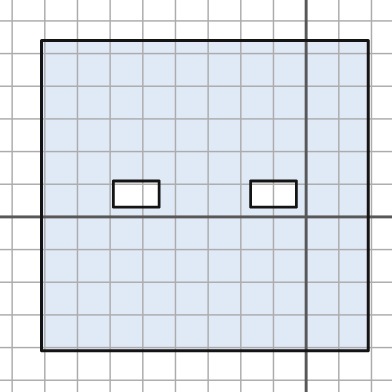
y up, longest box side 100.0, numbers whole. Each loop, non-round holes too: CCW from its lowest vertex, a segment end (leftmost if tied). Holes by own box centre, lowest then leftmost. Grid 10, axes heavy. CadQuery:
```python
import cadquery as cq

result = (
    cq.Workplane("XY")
    .moveTo(-81.0, -41.0)
    .lineTo(19.0, -41.0)
    .lineTo(19.0, 54.0)
    .lineTo(-81.0, 54.0)
    .close()
    .moveTo(-59.0, 3.0)
    .lineTo(-45.0, 3.0)
    .lineTo(-45.0, 11.0)
    .lineTo(-59.0, 11.0)
    .close()
    .moveTo(-17.0, 3.0)
    .lineTo(-3.0, 3.0)
    .lineTo(-3.0, 11.0)
    .lineTo(-17.0, 11.0)
    .close()
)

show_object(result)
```